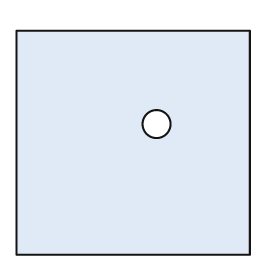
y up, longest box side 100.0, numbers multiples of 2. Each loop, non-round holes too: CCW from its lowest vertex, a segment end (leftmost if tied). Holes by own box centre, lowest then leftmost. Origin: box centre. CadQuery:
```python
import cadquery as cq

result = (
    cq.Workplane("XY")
    .moveTo(-50.0, -48.0)
    .lineTo(50.0, -48.0)
    .lineTo(50.0, 48.0)
    .lineTo(-50.0, 48.0)
    .close()
    .moveTo(10.0, 8.0)
    .circle(6.0)
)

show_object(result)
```